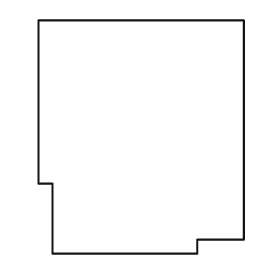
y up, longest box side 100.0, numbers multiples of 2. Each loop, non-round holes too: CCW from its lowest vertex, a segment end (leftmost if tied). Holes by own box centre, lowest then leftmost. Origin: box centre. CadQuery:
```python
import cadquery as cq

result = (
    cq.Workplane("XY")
    .moveTo(-38.0, -50.0)
    .lineTo(24.0, -50.0)
    .lineTo(24.0, -44.0)
    .lineTo(44.0, -44.0)
    .lineTo(44.0, 50.0)
    .lineTo(-44.0, 50.0)
    .lineTo(-44.0, -20.0)
    .lineTo(-38.0, -20.0)
    .close()
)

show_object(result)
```